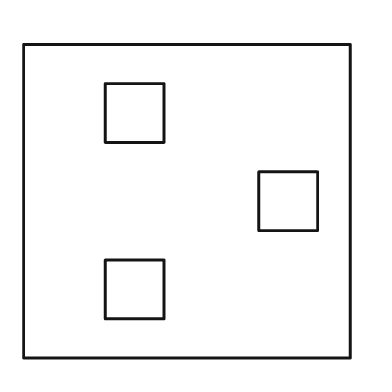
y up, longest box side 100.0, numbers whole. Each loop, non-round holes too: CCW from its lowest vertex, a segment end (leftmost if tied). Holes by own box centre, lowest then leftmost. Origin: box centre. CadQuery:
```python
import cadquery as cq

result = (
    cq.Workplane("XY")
    .moveTo(-50.0, -48.0)
    .lineTo(50.0, -48.0)
    .lineTo(50.0, 48.0)
    .lineTo(-50.0, 48.0)
    .close()
    .moveTo(-25.0, -36.0)
    .lineTo(-7.0, -36.0)
    .lineTo(-7.0, -18.0)
    .lineTo(-25.0, -18.0)
    .close()
    .moveTo(22.0, -9.0)
    .lineTo(40.0, -9.0)
    .lineTo(40.0, 9.0)
    .lineTo(22.0, 9.0)
    .close()
    .moveTo(-25.0, 18.0)
    .lineTo(-7.0, 18.0)
    .lineTo(-7.0, 36.0)
    .lineTo(-25.0, 36.0)
    .close()
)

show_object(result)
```